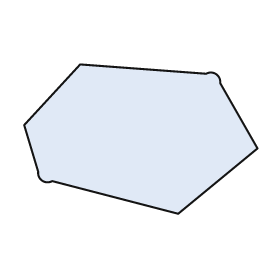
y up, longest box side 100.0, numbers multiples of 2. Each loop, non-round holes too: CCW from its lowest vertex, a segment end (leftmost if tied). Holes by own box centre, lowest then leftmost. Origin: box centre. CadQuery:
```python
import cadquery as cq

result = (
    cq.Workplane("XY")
    .moveTo(16.0, -32.0)
    .lineTo(50.0, -4.0)
    .lineTo(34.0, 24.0)
    .threePointArc((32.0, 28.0), (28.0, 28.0))
    .lineTo(-26.0, 32.0)
    .lineTo(-50.0, 6.0)
    .lineTo(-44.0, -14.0)
    .threePointArc((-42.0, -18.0), (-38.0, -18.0))
    .close()
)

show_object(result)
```